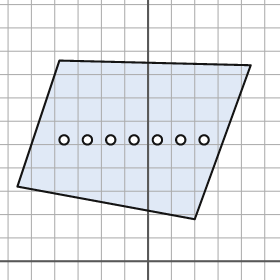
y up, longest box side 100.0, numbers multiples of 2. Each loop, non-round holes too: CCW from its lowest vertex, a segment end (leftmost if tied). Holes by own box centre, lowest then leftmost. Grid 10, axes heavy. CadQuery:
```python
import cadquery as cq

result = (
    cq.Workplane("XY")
    .moveTo(20.0, 18.0)
    .lineTo(44.0, 84.0)
    .lineTo(-38.0, 86.0)
    .lineTo(-56.0, 32.0)
    .close()
    .moveTo(-36.0, 52.0)
    .circle(2.0)
    .moveTo(-26.0, 52.0)
    .circle(2.0)
    .moveTo(-16.0, 52.0)
    .circle(2.0)
    .moveTo(-6.0, 52.0)
    .circle(2.0)
    .moveTo(4.0, 52.0)
    .circle(2.0)
    .moveTo(14.0, 52.0)
    .circle(2.0)
    .moveTo(24.0, 52.0)
    .circle(2.0)
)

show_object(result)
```